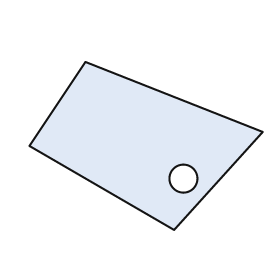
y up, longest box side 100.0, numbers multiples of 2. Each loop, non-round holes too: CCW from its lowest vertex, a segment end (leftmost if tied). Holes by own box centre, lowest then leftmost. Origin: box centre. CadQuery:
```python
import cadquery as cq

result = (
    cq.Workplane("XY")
    .moveTo(12.0, -36.0)
    .lineTo(50.0, 6.0)
    .lineTo(-26.0, 36.0)
    .lineTo(-50.0, 0.0)
    .close()
    .moveTo(16.0, -14.0)
    .circle(6.0)
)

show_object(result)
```